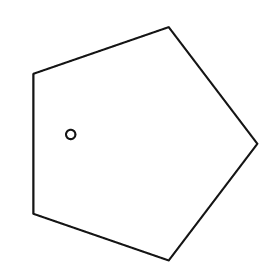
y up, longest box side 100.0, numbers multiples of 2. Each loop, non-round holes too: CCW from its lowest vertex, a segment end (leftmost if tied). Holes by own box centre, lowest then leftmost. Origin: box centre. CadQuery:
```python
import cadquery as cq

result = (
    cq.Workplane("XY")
    .moveTo(10.0, -50.0)
    .lineTo(48.0, 0.0)
    .lineTo(10.0, 50.0)
    .lineTo(-48.0, 30.0)
    .lineTo(-48.0, -30.0)
    .close()
    .moveTo(-32.0, 4.0)
    .circle(2.0)
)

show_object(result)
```